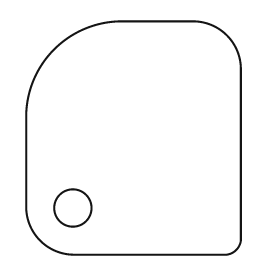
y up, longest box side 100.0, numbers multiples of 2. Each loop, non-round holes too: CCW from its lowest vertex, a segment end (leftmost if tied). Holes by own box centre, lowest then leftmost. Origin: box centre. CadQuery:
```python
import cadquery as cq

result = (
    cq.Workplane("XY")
    .moveTo(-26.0, -50.0)
    .lineTo(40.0, -50.0)
    .threePointArc((44.0, -48.0), (46.0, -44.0))
    .lineTo(46.0, 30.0)
    .threePointArc((40.0, 44.0), (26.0, 50.0))
    .lineTo(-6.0, 50.0)
    .threePointArc((-34.0, 38.0), (-46.0, 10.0))
    .lineTo(-46.0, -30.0)
    .threePointArc((-40.0, -44.0), (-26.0, -50.0))
    .close()
    .moveTo(-26.0, -30.0)
    .circle(8.0)
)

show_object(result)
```